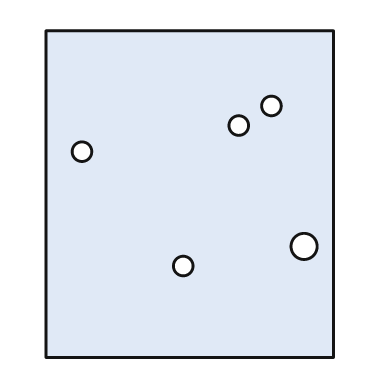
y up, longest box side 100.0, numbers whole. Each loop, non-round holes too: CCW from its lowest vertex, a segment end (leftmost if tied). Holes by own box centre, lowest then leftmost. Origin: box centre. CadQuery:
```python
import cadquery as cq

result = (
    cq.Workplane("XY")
    .moveTo(-44.0, -50.0)
    .lineTo(44.0, -50.0)
    .lineTo(44.0, 50.0)
    .lineTo(-44.0, 50.0)
    .close()
    .moveTo(-2.0, -22.0)
    .circle(3.0)
    .moveTo(35.0, -16.0)
    .circle(4.0)
    .moveTo(-33.0, 13.0)
    .circle(3.0)
    .moveTo(15.0, 21.0)
    .circle(3.0)
    .moveTo(25.0, 27.0)
    .circle(3.0)
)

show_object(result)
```